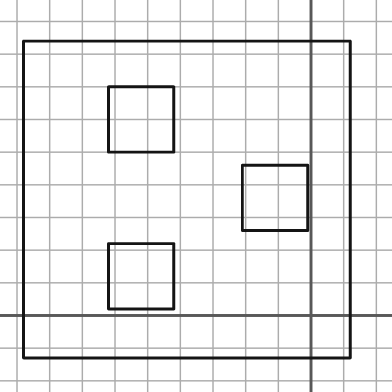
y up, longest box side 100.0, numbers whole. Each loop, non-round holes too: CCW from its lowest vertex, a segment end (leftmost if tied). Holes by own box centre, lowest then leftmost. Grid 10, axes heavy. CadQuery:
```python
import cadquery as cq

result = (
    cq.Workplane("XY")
    .moveTo(-88.0, -13.0)
    .lineTo(12.0, -13.0)
    .lineTo(12.0, 84.0)
    .lineTo(-88.0, 84.0)
    .close()
    .moveTo(-62.0, 2.0)
    .lineTo(-42.0, 2.0)
    .lineTo(-42.0, 22.0)
    .lineTo(-62.0, 22.0)
    .close()
    .moveTo(-21.0, 26.0)
    .lineTo(-1.0, 26.0)
    .lineTo(-1.0, 46.0)
    .lineTo(-21.0, 46.0)
    .close()
    .moveTo(-62.0, 50.0)
    .lineTo(-42.0, 50.0)
    .lineTo(-42.0, 70.0)
    .lineTo(-62.0, 70.0)
    .close()
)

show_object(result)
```